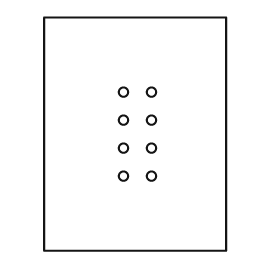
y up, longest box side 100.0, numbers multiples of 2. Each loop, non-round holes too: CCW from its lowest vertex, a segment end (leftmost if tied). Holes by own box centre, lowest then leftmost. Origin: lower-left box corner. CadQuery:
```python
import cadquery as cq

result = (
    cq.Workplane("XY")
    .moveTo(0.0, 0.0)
    .lineTo(78.0, 0.0)
    .lineTo(78.0, 100.0)
    .lineTo(0.0, 100.0)
    .close()
    .moveTo(34.0, 32.0)
    .circle(2.0)
    .moveTo(46.0, 32.0)
    .circle(2.0)
    .moveTo(34.0, 44.0)
    .circle(2.0)
    .moveTo(46.0, 44.0)
    .circle(2.0)
    .moveTo(34.0, 56.0)
    .circle(2.0)
    .moveTo(46.0, 56.0)
    .circle(2.0)
    .moveTo(34.0, 68.0)
    .circle(2.0)
    .moveTo(46.0, 68.0)
    .circle(2.0)
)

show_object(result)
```